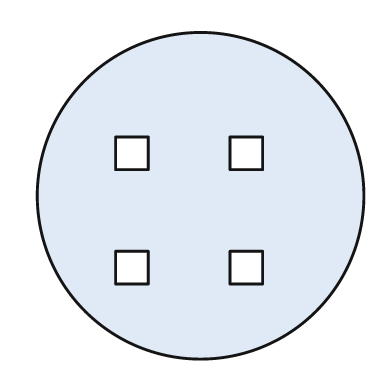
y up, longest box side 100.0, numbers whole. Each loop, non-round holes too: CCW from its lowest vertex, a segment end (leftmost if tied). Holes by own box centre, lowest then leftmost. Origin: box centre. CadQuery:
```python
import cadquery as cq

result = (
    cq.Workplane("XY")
    .moveTo(0.0, 0.0)
    .circle(50.0)
    .moveTo(-26.0, -27.0)
    .lineTo(-16.0, -27.0)
    .lineTo(-16.0, -17.0)
    .lineTo(-26.0, -17.0)
    .close()
    .moveTo(9.0, -27.0)
    .lineTo(19.0, -27.0)
    .lineTo(19.0, -17.0)
    .lineTo(9.0, -17.0)
    .close()
    .moveTo(-26.0, 8.0)
    .lineTo(-16.0, 8.0)
    .lineTo(-16.0, 18.0)
    .lineTo(-26.0, 18.0)
    .close()
    .moveTo(9.0, 8.0)
    .lineTo(19.0, 8.0)
    .lineTo(19.0, 18.0)
    .lineTo(9.0, 18.0)
    .close()
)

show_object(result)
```